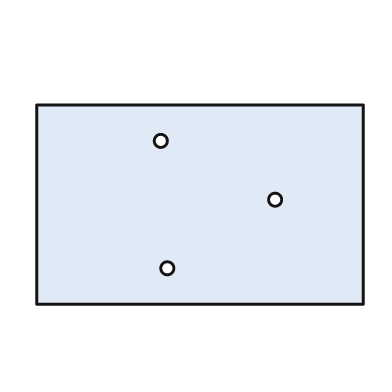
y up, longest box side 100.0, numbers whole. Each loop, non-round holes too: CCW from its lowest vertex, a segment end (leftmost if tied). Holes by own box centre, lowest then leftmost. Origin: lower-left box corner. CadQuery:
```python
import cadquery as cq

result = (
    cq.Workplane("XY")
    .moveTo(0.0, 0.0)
    .lineTo(100.0, 0.0)
    .lineTo(100.0, 61.0)
    .lineTo(0.0, 61.0)
    .close()
    .moveTo(40.0, 11.0)
    .circle(2.0)
    .moveTo(73.0, 32.0)
    .circle(2.0)
    .moveTo(38.0, 50.0)
    .circle(2.0)
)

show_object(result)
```